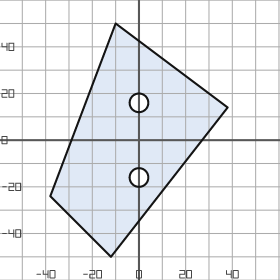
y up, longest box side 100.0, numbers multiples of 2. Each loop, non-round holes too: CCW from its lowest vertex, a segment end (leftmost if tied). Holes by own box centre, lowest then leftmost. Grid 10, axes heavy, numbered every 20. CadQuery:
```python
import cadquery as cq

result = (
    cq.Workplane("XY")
    .moveTo(-12.0, -50.0)
    .lineTo(38.0, 14.0)
    .lineTo(-10.0, 50.0)
    .lineTo(-38.0, -24.0)
    .close()
    .moveTo(0.0, -16.0)
    .circle(4.0)
    .moveTo(0.0, 16.0)
    .circle(4.0)
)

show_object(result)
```